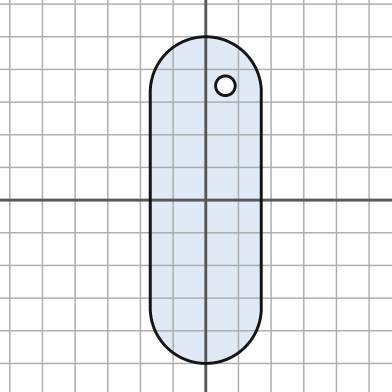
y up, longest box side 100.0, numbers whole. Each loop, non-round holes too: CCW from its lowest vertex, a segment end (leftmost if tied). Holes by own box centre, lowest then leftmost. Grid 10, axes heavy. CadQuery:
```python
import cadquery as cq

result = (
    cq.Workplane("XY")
    .moveTo(-17.0, -33.0)
    .threePointArc((0.0, -50.0), (17.0, -33.0))
    .lineTo(17.0, 33.0)
    .threePointArc((0.0, 50.0), (-17.0, 33.0))
    .close()
    .moveTo(6.0, 35.0)
    .circle(3.0)
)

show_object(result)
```